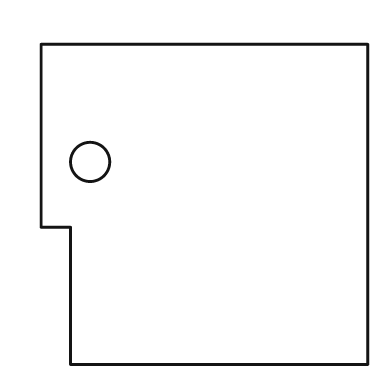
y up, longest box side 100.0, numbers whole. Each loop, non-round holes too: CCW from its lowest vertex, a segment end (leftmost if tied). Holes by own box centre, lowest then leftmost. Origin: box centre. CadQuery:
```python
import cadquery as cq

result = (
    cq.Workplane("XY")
    .moveTo(-41.0, -49.0)
    .lineTo(50.0, -49.0)
    .lineTo(50.0, 49.0)
    .lineTo(-50.0, 49.0)
    .lineTo(-50.0, -7.0)
    .lineTo(-41.0, -7.0)
    .close()
    .moveTo(-35.0, 13.0)
    .circle(6.0)
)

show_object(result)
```